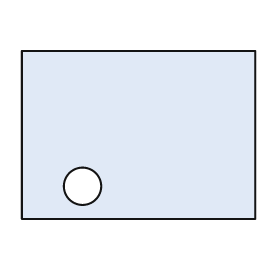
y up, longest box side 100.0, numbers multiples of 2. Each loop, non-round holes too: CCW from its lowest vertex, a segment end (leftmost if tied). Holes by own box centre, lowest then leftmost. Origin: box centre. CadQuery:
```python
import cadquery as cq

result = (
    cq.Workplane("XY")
    .moveTo(-50.0, -36.0)
    .lineTo(50.0, -36.0)
    .lineTo(50.0, 36.0)
    .lineTo(-50.0, 36.0)
    .close()
    .moveTo(-24.0, -22.0)
    .circle(8.0)
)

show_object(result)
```